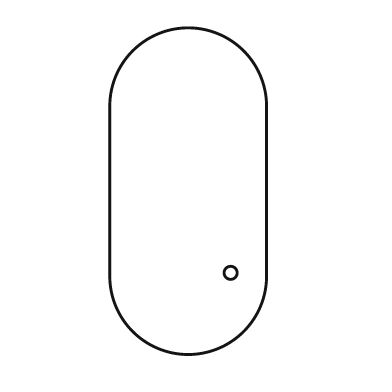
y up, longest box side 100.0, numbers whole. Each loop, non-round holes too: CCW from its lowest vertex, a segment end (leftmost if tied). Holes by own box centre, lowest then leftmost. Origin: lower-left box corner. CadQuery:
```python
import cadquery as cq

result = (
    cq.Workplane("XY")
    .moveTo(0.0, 24.0)
    .threePointArc((24.0, 0.0), (48.0, 24.0))
    .lineTo(48.0, 76.0)
    .threePointArc((24.0, 100.0), (0.0, 76.0))
    .close()
    .moveTo(37.0, 25.0)
    .circle(2.0)
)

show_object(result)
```